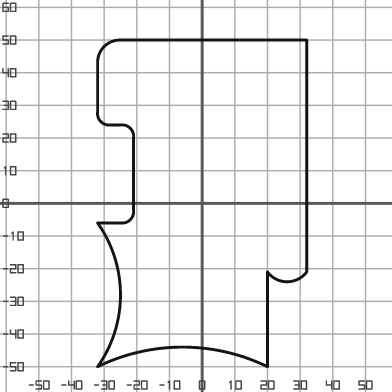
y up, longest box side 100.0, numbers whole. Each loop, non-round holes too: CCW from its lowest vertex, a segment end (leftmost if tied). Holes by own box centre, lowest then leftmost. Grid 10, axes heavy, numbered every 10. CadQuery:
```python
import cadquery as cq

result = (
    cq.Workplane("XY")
    .moveTo(-32.0, -50.0)
    .threePointArc((-6.0, -44.0), (20.0, -50.0))
    .lineTo(20.0, -21.0)
    .threePointArc((26.0, -24.0), (32.0, -21.0))
    .lineTo(32.0, 50.0)
    .lineTo(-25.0, 50.0)
    .threePointArc((-30.0, 48.0), (-32.0, 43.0))
    .lineTo(-32.0, 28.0)
    .threePointArc((-31.0, 25.0), (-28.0, 24.0))
    .lineTo(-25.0, 24.0)
    .threePointArc((-22.0, 23.0), (-21.0, 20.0))
    .lineTo(-21.0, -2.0)
    .threePointArc((-22.0, -5.0), (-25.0, -6.0))
    .lineTo(-32.0, -6.0)
    .threePointArc((-25.0, -28.0), (-32.0, -50.0))
    .close()
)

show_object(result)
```